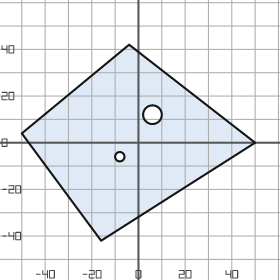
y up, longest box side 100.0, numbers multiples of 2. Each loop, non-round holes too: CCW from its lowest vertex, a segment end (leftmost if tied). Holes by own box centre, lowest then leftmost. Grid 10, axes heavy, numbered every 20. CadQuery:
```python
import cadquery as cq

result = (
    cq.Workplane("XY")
    .moveTo(-16.0, -42.0)
    .lineTo(50.0, 0.0)
    .lineTo(-4.0, 42.0)
    .lineTo(-50.0, 4.0)
    .close()
    .moveTo(-8.0, -6.0)
    .circle(2.0)
    .moveTo(6.0, 12.0)
    .circle(4.0)
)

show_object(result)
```